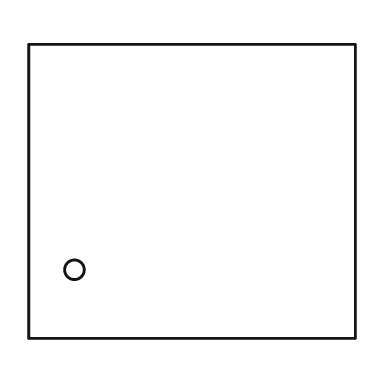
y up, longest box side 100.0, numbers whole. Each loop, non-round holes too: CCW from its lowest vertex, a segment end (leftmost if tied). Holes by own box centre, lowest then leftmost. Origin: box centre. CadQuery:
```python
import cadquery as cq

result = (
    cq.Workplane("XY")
    .moveTo(-50.0, -45.0)
    .lineTo(50.0, -45.0)
    .lineTo(50.0, 45.0)
    .lineTo(-50.0, 45.0)
    .close()
    .moveTo(-36.0, -24.0)
    .circle(3.0)
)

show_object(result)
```